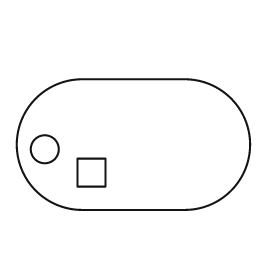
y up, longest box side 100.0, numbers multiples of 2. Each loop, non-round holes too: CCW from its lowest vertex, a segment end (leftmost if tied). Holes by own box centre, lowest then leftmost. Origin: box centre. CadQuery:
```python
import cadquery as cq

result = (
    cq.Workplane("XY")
    .moveTo(-22.0, -28.0)
    .lineTo(22.0, -28.0)
    .threePointArc((50.0, 0.0), (22.0, 28.0))
    .lineTo(-22.0, 28.0)
    .threePointArc((-50.0, 0.0), (-22.0, -28.0))
    .close()
    .moveTo(-24.0, -18.0)
    .lineTo(-12.0, -18.0)
    .lineTo(-12.0, -6.0)
    .lineTo(-24.0, -6.0)
    .close()
    .moveTo(-38.0, -2.0)
    .circle(6.0)
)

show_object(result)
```